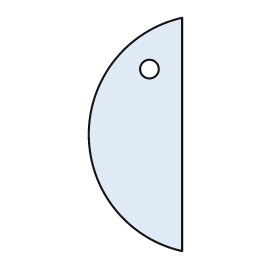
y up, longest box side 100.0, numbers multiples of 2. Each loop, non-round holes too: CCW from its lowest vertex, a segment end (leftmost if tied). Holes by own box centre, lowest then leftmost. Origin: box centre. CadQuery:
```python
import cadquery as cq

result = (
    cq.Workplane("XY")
    .moveTo(20.0, -50.0)
    .lineTo(20.0, 50.0)
    .threePointArc((-20.0, 0.0), (20.0, -50.0))
    .close()
    .moveTo(6.0, 28.0)
    .circle(4.0)
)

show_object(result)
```